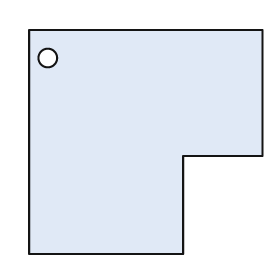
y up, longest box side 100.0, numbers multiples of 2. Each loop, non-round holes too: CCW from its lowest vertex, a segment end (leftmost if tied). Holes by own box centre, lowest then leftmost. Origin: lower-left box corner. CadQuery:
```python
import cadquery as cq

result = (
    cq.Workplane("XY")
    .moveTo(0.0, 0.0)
    .lineTo(66.0, 0.0)
    .lineTo(66.0, 42.0)
    .lineTo(100.0, 42.0)
    .lineTo(100.0, 96.0)
    .lineTo(0.0, 96.0)
    .close()
    .moveTo(8.0, 84.0)
    .circle(4.0)
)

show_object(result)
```